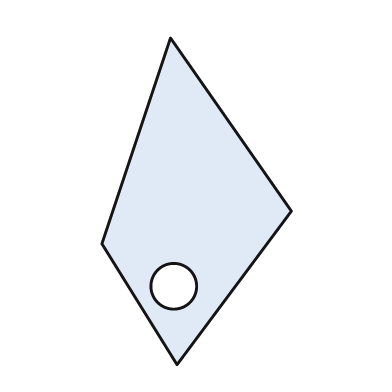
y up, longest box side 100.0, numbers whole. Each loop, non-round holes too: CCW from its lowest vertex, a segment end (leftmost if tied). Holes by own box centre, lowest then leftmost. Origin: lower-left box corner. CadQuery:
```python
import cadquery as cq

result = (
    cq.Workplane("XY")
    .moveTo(23.0, 0.0)
    .lineTo(58.0, 47.0)
    .lineTo(21.0, 100.0)
    .lineTo(0.0, 37.0)
    .close()
    .moveTo(22.0, 24.0)
    .circle(7.0)
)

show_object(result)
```